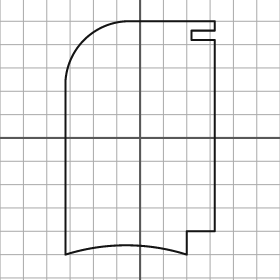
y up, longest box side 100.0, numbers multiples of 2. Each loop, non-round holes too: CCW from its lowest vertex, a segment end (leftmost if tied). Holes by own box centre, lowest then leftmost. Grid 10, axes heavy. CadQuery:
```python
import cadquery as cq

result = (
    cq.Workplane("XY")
    .moveTo(-32.0, -50.0)
    .threePointArc((-6.0, -46.0), (20.0, -50.0))
    .lineTo(20.0, -40.0)
    .lineTo(32.0, -40.0)
    .lineTo(32.0, 42.0)
    .lineTo(22.0, 42.0)
    .lineTo(22.0, 46.0)
    .lineTo(32.0, 46.0)
    .lineTo(32.0, 50.0)
    .lineTo(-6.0, 50.0)
    .threePointArc((-24.0, 42.0), (-32.0, 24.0))
    .close()
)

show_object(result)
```